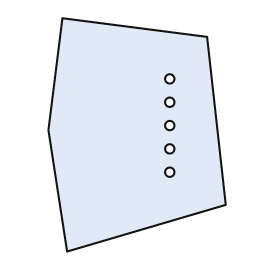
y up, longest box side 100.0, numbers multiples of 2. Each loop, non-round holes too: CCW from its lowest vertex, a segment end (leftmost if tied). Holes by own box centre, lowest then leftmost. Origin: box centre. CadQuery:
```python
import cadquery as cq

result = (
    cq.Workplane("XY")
    .moveTo(-30.0, -50.0)
    .lineTo(38.0, -30.0)
    .lineTo(30.0, 42.0)
    .lineTo(-32.0, 50.0)
    .lineTo(-38.0, 2.0)
    .close()
    .moveTo(14.0, -16.0)
    .circle(2.0)
    .moveTo(14.0, -6.0)
    .circle(2.0)
    .moveTo(14.0, 4.0)
    .circle(2.0)
    .moveTo(14.0, 14.0)
    .circle(2.0)
    .moveTo(14.0, 24.0)
    .circle(2.0)
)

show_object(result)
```